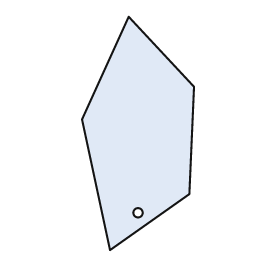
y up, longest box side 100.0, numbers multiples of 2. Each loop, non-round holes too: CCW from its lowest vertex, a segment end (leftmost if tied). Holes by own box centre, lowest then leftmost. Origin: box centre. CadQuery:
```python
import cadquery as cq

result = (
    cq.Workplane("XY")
    .moveTo(-12.0, -50.0)
    .lineTo(22.0, -26.0)
    .lineTo(24.0, 20.0)
    .lineTo(-4.0, 50.0)
    .lineTo(-24.0, 6.0)
    .close()
    .moveTo(0.0, -34.0)
    .circle(2.0)
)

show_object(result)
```